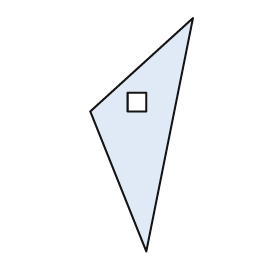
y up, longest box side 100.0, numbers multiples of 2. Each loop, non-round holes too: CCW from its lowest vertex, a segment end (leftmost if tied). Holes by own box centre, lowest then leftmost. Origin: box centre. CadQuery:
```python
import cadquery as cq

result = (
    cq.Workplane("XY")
    .moveTo(2.0, -50.0)
    .lineTo(22.0, 50.0)
    .lineTo(-22.0, 10.0)
    .close()
    .moveTo(-6.0, 10.0)
    .lineTo(2.0, 10.0)
    .lineTo(2.0, 18.0)
    .lineTo(-6.0, 18.0)
    .close()
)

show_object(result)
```